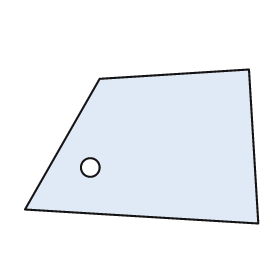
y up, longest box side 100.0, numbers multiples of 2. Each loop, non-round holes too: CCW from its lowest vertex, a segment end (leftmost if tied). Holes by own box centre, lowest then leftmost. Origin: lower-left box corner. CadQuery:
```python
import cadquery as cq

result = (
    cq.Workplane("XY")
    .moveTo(100.0, 0.0)
    .lineTo(96.0, 66.0)
    .lineTo(32.0, 62.0)
    .lineTo(0.0, 6.0)
    .close()
    .moveTo(28.0, 24.0)
    .circle(4.0)
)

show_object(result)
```